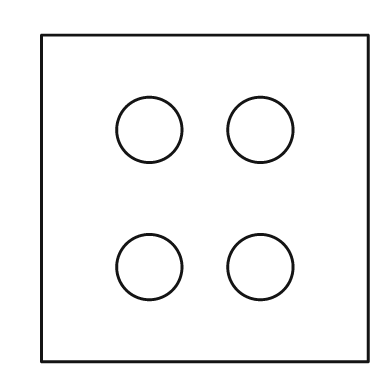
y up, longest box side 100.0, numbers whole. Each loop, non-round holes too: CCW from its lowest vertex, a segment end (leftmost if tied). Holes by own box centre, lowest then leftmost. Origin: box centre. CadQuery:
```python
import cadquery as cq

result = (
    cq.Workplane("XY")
    .moveTo(-50.0, -50.0)
    .lineTo(50.0, -50.0)
    .lineTo(50.0, 50.0)
    .lineTo(-50.0, 50.0)
    .close()
    .moveTo(-17.0, -21.0)
    .circle(10.0)
    .moveTo(17.0, -21.0)
    .circle(10.0)
    .moveTo(-17.0, 21.0)
    .circle(10.0)
    .moveTo(17.0, 21.0)
    .circle(10.0)
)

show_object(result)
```